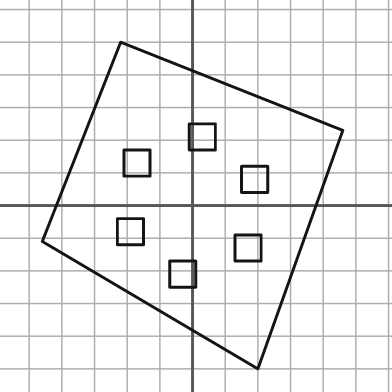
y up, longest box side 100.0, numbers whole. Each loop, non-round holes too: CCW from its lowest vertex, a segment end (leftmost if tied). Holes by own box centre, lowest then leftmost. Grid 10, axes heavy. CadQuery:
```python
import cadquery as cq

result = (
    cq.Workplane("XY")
    .moveTo(20.0, -50.0)
    .lineTo(46.0, 23.0)
    .lineTo(-22.0, 50.0)
    .lineTo(-46.0, -11.0)
    .close()
    .moveTo(-7.0, -25.0)
    .lineTo(1.0, -25.0)
    .lineTo(1.0, -17.0)
    .lineTo(-7.0, -17.0)
    .close()
    .moveTo(13.0, -17.0)
    .lineTo(21.0, -17.0)
    .lineTo(21.0, -9.0)
    .lineTo(13.0, -9.0)
    .close()
    .moveTo(-23.0, -12.0)
    .lineTo(-15.0, -12.0)
    .lineTo(-15.0, -4.0)
    .lineTo(-23.0, -4.0)
    .close()
    .moveTo(15.0, 4.0)
    .lineTo(23.0, 4.0)
    .lineTo(23.0, 12.0)
    .lineTo(15.0, 12.0)
    .close()
    .moveTo(-21.0, 9.0)
    .lineTo(-13.0, 9.0)
    .lineTo(-13.0, 17.0)
    .lineTo(-21.0, 17.0)
    .close()
    .moveTo(-1.0, 17.0)
    .lineTo(7.0, 17.0)
    .lineTo(7.0, 25.0)
    .lineTo(-1.0, 25.0)
    .close()
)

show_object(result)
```